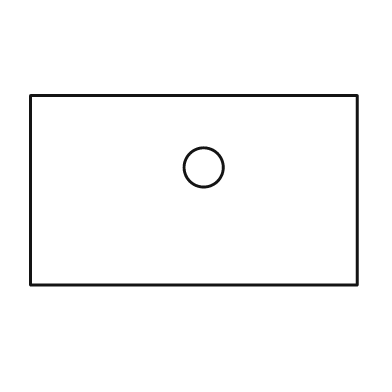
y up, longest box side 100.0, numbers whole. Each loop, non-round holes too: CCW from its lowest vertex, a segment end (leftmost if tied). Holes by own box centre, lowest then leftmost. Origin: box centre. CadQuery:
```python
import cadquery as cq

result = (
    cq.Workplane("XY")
    .moveTo(-50.0, -29.0)
    .lineTo(50.0, -29.0)
    .lineTo(50.0, 29.0)
    .lineTo(-50.0, 29.0)
    .close()
    .moveTo(3.0, 7.0)
    .circle(6.0)
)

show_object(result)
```